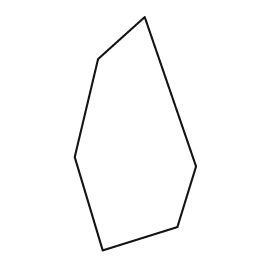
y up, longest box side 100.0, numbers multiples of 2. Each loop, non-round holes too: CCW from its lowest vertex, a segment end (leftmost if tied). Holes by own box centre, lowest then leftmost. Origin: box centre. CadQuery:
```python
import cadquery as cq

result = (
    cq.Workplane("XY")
    .moveTo(-14.0, -50.0)
    .lineTo(18.0, -40.0)
    .lineTo(26.0, -14.0)
    .lineTo(4.0, 50.0)
    .lineTo(-16.0, 32.0)
    .lineTo(-26.0, -10.0)
    .close()
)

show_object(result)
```